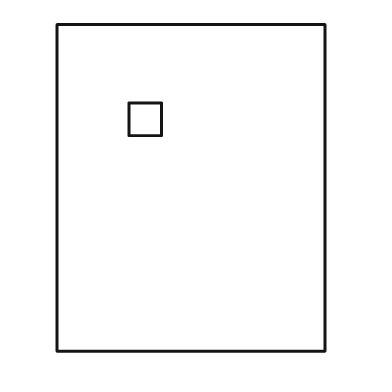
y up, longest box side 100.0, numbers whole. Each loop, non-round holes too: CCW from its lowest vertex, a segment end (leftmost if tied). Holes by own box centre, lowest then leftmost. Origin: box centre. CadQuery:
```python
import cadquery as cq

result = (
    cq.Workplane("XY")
    .moveTo(-41.0, -50.0)
    .lineTo(41.0, -50.0)
    .lineTo(41.0, 50.0)
    .lineTo(-41.0, 50.0)
    .close()
    .moveTo(-19.0, 16.0)
    .lineTo(-9.0, 16.0)
    .lineTo(-9.0, 26.0)
    .lineTo(-19.0, 26.0)
    .close()
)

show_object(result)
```